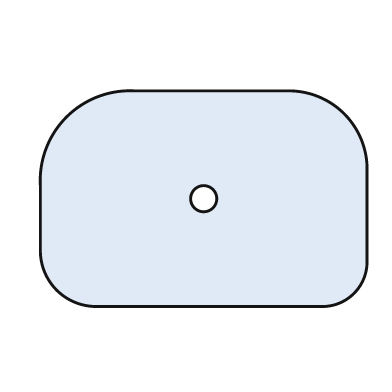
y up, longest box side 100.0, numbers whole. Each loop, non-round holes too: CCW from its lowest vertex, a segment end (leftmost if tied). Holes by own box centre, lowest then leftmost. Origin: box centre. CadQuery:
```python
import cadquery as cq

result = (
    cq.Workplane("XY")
    .moveTo(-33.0, -33.0)
    .lineTo(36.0, -33.0)
    .threePointArc((46.0, -29.0), (50.0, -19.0))
    .lineTo(50.0, 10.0)
    .threePointArc((43.0, 26.0), (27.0, 33.0))
    .lineTo(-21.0, 33.0)
    .threePointArc((-42.0, 25.0), (-50.0, 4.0))
    .lineTo(-50.0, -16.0)
    .threePointArc((-45.0, -28.0), (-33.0, -33.0))
    .close()
    .moveTo(0.0, 0.0)
    .circle(4.0)
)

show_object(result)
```